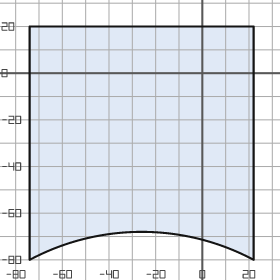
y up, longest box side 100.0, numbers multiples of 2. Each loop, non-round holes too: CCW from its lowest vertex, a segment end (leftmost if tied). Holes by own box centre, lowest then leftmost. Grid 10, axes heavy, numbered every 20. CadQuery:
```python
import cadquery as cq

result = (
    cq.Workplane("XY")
    .moveTo(-74.0, -80.0)
    .threePointArc((-26.0, -68.0), (22.0, -80.0))
    .lineTo(22.0, 20.0)
    .lineTo(-74.0, 20.0)
    .close()
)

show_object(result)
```